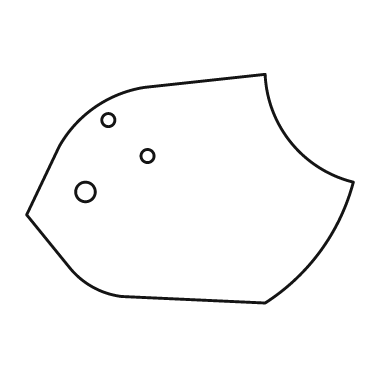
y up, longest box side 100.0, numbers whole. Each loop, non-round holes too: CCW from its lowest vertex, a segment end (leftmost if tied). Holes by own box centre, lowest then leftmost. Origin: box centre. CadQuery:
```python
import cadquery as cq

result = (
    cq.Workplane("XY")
    .moveTo(23.0, -35.0)
    .threePointArc((40.0, -19.0), (50.0, 2.0))
    .threePointArc((31.0, 14.0), (23.0, 35.0))
    .lineTo(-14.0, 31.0)
    .threePointArc((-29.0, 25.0), (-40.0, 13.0))
    .lineTo(-50.0, -8.0)
    .lineTo(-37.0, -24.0)
    .threePointArc((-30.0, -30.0), (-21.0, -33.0))
    .close()
    .moveTo(-32.0, -1.0)
    .circle(3.0)
    .moveTo(-13.0, 10.0)
    .circle(2.0)
    .moveTo(-25.0, 21.0)
    .circle(2.0)
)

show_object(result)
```